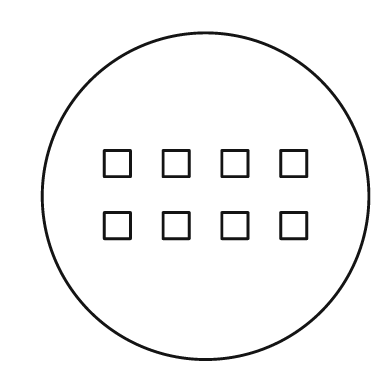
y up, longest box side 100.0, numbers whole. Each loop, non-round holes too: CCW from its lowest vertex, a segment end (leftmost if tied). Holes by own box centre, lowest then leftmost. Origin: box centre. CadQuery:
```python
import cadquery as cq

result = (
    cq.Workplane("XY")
    .moveTo(0.0, 0.0)
    .circle(50.0)
    .moveTo(-31.0, -13.0)
    .lineTo(-23.0, -13.0)
    .lineTo(-23.0, -5.0)
    .lineTo(-31.0, -5.0)
    .close()
    .moveTo(-13.0, -13.0)
    .lineTo(-5.0, -13.0)
    .lineTo(-5.0, -5.0)
    .lineTo(-13.0, -5.0)
    .close()
    .moveTo(5.0, -13.0)
    .lineTo(13.0, -13.0)
    .lineTo(13.0, -5.0)
    .lineTo(5.0, -5.0)
    .close()
    .moveTo(23.0, -13.0)
    .lineTo(31.0, -13.0)
    .lineTo(31.0, -5.0)
    .lineTo(23.0, -5.0)
    .close()
    .moveTo(-31.0, 6.0)
    .lineTo(-23.0, 6.0)
    .lineTo(-23.0, 14.0)
    .lineTo(-31.0, 14.0)
    .close()
    .moveTo(-13.0, 6.0)
    .lineTo(-5.0, 6.0)
    .lineTo(-5.0, 14.0)
    .lineTo(-13.0, 14.0)
    .close()
    .moveTo(5.0, 6.0)
    .lineTo(13.0, 6.0)
    .lineTo(13.0, 14.0)
    .lineTo(5.0, 14.0)
    .close()
    .moveTo(23.0, 6.0)
    .lineTo(31.0, 6.0)
    .lineTo(31.0, 14.0)
    .lineTo(23.0, 14.0)
    .close()
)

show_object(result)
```